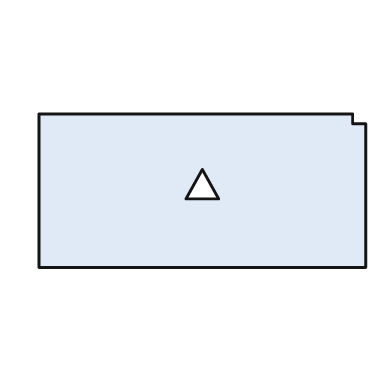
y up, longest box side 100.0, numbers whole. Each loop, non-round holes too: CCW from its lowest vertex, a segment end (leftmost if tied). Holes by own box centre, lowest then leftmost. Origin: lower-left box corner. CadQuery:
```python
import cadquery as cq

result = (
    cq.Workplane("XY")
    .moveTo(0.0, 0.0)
    .lineTo(100.0, 0.0)
    .lineTo(100.0, 44.0)
    .lineTo(96.0, 44.0)
    .lineTo(96.0, 47.0)
    .lineTo(0.0, 47.0)
    .close()
    .moveTo(45.0, 21.0)
    .lineTo(55.0, 21.0)
    .lineTo(50.0, 30.0)
    .close()
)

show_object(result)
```